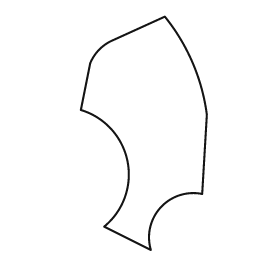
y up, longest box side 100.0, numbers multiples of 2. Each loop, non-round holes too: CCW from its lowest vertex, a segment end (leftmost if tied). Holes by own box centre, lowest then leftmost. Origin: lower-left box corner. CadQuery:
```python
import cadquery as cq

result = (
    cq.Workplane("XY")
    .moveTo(30.0, 0.0)
    .threePointArc((34.0, 18.0), (52.0, 24.0))
    .lineTo(54.0, 58.0)
    .threePointArc((48.0, 80.0), (36.0, 100.0))
    .lineTo(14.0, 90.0)
    .threePointArc((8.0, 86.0), (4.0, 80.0))
    .lineTo(0.0, 60.0)
    .threePointArc((20.0, 38.0), (10.0, 10.0))
    .close()
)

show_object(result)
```